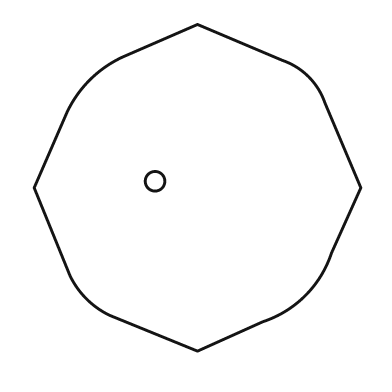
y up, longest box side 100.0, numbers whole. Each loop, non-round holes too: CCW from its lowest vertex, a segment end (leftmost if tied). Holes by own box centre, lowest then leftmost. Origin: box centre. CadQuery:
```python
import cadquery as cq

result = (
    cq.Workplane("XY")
    .moveTo(0.0, -50.0)
    .lineTo(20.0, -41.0)
    .threePointArc((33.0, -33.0), (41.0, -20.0))
    .lineTo(50.0, 0.0)
    .lineTo(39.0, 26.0)
    .threePointArc((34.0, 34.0), (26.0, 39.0))
    .lineTo(0.0, 50.0)
    .lineTo(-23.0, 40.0)
    .threePointArc((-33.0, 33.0), (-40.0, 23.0))
    .lineTo(-50.0, 0.0)
    .lineTo(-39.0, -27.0)
    .threePointArc((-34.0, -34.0), (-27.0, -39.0))
    .close()
    .moveTo(-13.0, 2.0)
    .circle(3.0)
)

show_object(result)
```